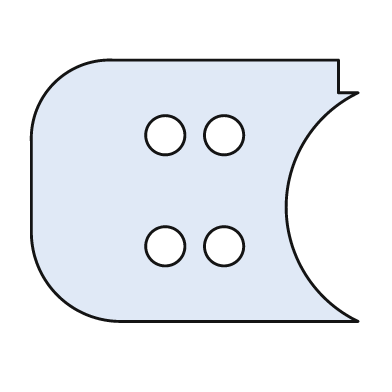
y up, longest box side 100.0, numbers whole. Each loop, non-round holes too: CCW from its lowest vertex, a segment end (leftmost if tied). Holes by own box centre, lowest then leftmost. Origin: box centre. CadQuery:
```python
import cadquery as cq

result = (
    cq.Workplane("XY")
    .moveTo(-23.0, -40.0)
    .lineTo(50.0, -40.0)
    .threePointArc((28.0, -5.0), (50.0, 30.0))
    .lineTo(44.0, 30.0)
    .lineTo(44.0, 40.0)
    .lineTo(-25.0, 40.0)
    .threePointArc((-43.0, 33.0), (-50.0, 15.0))
    .lineTo(-50.0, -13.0)
    .threePointArc((-42.0, -32.0), (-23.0, -40.0))
    .close()
    .moveTo(-9.0, -17.0)
    .circle(6.0)
    .moveTo(9.0, -17.0)
    .circle(6.0)
    .moveTo(-9.0, 17.0)
    .circle(6.0)
    .moveTo(9.0, 17.0)
    .circle(6.0)
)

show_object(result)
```